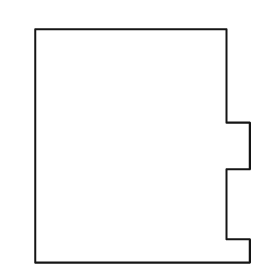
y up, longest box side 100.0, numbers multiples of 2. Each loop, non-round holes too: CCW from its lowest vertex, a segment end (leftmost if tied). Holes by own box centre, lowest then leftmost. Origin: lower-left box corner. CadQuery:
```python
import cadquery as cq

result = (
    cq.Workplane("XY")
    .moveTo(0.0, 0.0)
    .lineTo(92.0, 0.0)
    .lineTo(92.0, 10.0)
    .lineTo(82.0, 10.0)
    .lineTo(82.0, 40.0)
    .lineTo(92.0, 40.0)
    .lineTo(92.0, 60.0)
    .lineTo(82.0, 60.0)
    .lineTo(82.0, 100.0)
    .lineTo(0.0, 100.0)
    .close()
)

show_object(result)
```